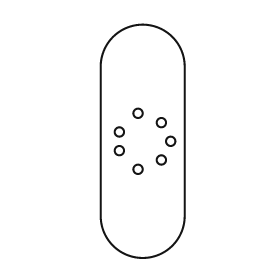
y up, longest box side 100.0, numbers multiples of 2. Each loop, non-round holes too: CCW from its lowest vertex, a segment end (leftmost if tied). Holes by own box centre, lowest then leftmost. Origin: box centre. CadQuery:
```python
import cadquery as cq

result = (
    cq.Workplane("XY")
    .moveTo(-18.0, -32.0)
    .threePointArc((0.0, -50.0), (18.0, -32.0))
    .lineTo(18.0, 32.0)
    .threePointArc((0.0, 50.0), (-18.0, 32.0))
    .close()
    .moveTo(-2.0, -12.0)
    .circle(2.0)
    .moveTo(8.0, -8.0)
    .circle(2.0)
    .moveTo(-10.0, -4.0)
    .circle(2.0)
    .moveTo(12.0, 0.0)
    .circle(2.0)
    .moveTo(-10.0, 4.0)
    .circle(2.0)
    .moveTo(8.0, 8.0)
    .circle(2.0)
    .moveTo(-2.0, 12.0)
    .circle(2.0)
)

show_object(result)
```